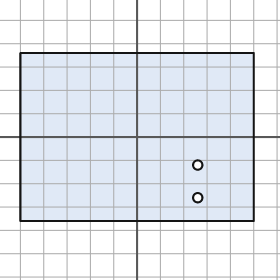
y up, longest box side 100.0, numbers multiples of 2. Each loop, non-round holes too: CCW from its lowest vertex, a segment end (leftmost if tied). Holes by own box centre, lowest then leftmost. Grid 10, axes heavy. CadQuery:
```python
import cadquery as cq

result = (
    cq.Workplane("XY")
    .moveTo(-50.0, -36.0)
    .lineTo(50.0, -36.0)
    .lineTo(50.0, 36.0)
    .lineTo(-50.0, 36.0)
    .close()
    .moveTo(26.0, -26.0)
    .circle(2.0)
    .moveTo(26.0, -12.0)
    .circle(2.0)
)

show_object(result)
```